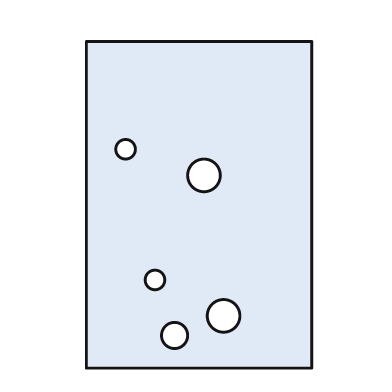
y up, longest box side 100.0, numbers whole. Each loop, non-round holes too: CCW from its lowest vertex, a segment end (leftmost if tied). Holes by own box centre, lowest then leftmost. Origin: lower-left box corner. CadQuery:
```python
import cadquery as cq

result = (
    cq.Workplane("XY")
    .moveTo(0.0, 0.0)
    .lineTo(69.0, 0.0)
    .lineTo(69.0, 100.0)
    .lineTo(0.0, 100.0)
    .close()
    .moveTo(27.0, 10.0)
    .circle(4.0)
    .moveTo(42.0, 16.0)
    .circle(5.0)
    .moveTo(21.0, 27.0)
    .circle(3.0)
    .moveTo(36.0, 59.0)
    .circle(5.0)
    .moveTo(12.0, 67.0)
    .circle(3.0)
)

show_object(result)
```